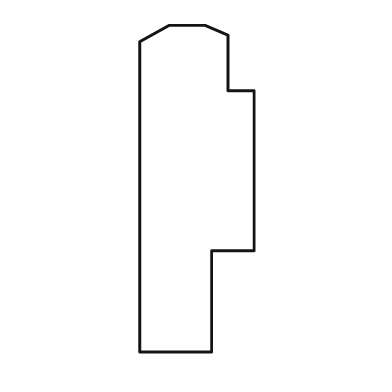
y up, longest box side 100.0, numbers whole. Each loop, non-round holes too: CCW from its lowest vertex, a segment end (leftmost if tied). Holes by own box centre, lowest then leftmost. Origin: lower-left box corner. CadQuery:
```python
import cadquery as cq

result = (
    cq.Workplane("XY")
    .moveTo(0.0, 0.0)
    .lineTo(22.0, 0.0)
    .lineTo(22.0, 31.0)
    .lineTo(35.0, 31.0)
    .lineTo(35.0, 80.0)
    .lineTo(27.0, 80.0)
    .lineTo(27.0, 97.0)
    .lineTo(20.0, 100.0)
    .lineTo(9.0, 100.0)
    .lineTo(0.0, 95.0)
    .close()
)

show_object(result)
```